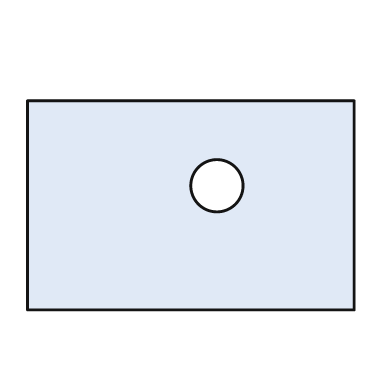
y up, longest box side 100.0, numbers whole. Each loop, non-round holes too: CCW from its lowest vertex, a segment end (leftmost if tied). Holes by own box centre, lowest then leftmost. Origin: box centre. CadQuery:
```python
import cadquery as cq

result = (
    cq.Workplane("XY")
    .moveTo(-50.0, -32.0)
    .lineTo(50.0, -32.0)
    .lineTo(50.0, 32.0)
    .lineTo(-50.0, 32.0)
    .close()
    .moveTo(8.0, 6.0)
    .circle(8.0)
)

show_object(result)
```